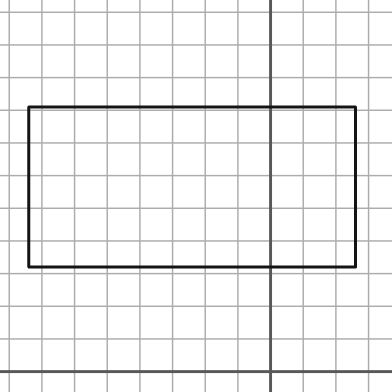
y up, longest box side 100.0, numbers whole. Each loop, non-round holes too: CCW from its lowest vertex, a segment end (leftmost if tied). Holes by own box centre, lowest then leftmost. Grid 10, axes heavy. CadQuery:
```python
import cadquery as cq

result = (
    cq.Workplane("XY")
    .moveTo(-74.0, 32.0)
    .lineTo(26.0, 32.0)
    .lineTo(26.0, 81.0)
    .lineTo(-74.0, 81.0)
    .close()
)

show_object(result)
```